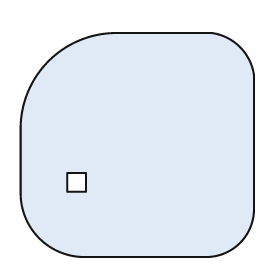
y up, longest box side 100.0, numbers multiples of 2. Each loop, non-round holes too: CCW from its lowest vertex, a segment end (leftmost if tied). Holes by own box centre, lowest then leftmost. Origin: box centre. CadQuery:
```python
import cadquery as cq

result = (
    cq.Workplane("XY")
    .moveTo(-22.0, -48.0)
    .lineTo(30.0, -48.0)
    .threePointArc((44.0, -42.0), (50.0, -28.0))
    .lineTo(50.0, 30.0)
    .threePointArc((44.0, 42.0), (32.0, 48.0))
    .lineTo(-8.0, 48.0)
    .threePointArc((-38.0, 36.0), (-50.0, 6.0))
    .lineTo(-50.0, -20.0)
    .threePointArc((-42.0, -40.0), (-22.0, -48.0))
    .close()
    .moveTo(-30.0, -20.0)
    .lineTo(-22.0, -20.0)
    .lineTo(-22.0, -12.0)
    .lineTo(-30.0, -12.0)
    .close()
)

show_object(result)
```